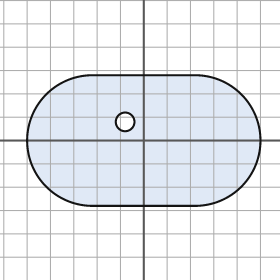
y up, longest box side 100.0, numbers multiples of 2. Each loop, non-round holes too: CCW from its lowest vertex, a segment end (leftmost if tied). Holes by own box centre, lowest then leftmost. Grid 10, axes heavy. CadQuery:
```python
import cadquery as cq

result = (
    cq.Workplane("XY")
    .moveTo(-22.0, -28.0)
    .lineTo(22.0, -28.0)
    .threePointArc((50.0, 0.0), (22.0, 28.0))
    .lineTo(-22.0, 28.0)
    .threePointArc((-50.0, 0.0), (-22.0, -28.0))
    .close()
    .moveTo(-8.0, 8.0)
    .circle(4.0)
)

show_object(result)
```